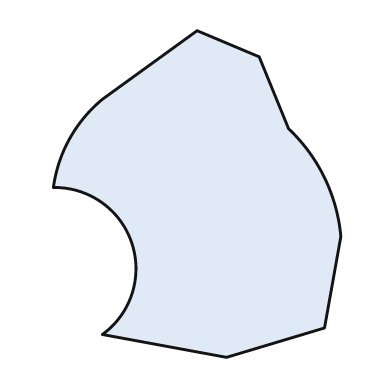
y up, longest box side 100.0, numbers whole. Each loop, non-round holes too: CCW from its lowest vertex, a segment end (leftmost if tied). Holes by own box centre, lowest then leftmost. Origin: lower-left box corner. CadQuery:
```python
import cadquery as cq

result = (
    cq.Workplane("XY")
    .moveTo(53.0, 0.0)
    .lineTo(83.0, 9.0)
    .lineTo(88.0, 37.0)
    .threePointArc((83.0, 55.0), (72.0, 70.0))
    .lineTo(63.0, 92.0)
    .lineTo(44.0, 100.0)
    .lineTo(15.0, 79.0)
    .threePointArc((5.0, 67.0), (0.0, 52.0))
    .threePointArc((24.0, 35.0), (15.0, 7.0))
    .close()
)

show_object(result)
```